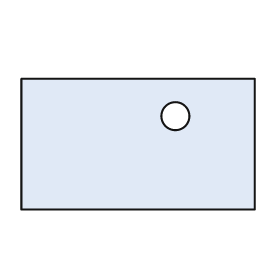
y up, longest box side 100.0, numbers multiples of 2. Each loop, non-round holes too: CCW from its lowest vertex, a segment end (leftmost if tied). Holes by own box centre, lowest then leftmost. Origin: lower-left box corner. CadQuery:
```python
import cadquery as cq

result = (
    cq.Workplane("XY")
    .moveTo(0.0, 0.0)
    .lineTo(100.0, 0.0)
    .lineTo(100.0, 56.0)
    .lineTo(0.0, 56.0)
    .close()
    .moveTo(66.0, 40.0)
    .circle(6.0)
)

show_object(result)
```